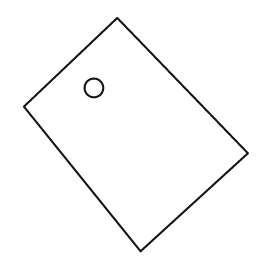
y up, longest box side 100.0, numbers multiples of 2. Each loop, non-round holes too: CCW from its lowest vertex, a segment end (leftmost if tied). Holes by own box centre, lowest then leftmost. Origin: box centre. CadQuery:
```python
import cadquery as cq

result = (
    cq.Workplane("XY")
    .moveTo(2.0, -50.0)
    .lineTo(48.0, -8.0)
    .lineTo(-8.0, 50.0)
    .lineTo(-48.0, 12.0)
    .close()
    .moveTo(-18.0, 20.0)
    .circle(4.0)
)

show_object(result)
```